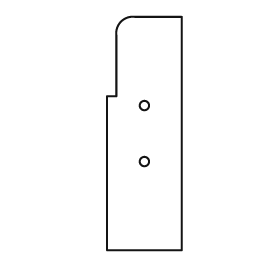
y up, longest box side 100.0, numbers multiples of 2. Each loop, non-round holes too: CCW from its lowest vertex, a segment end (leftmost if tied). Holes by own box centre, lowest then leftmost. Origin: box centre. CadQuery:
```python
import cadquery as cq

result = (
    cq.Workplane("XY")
    .moveTo(-16.0, -50.0)
    .lineTo(16.0, -50.0)
    .lineTo(16.0, 50.0)
    .lineTo(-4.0, 50.0)
    .threePointArc((-10.0, 48.0), (-12.0, 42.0))
    .lineTo(-12.0, 16.0)
    .lineTo(-16.0, 16.0)
    .close()
    .moveTo(0.0, -12.0)
    .circle(2.0)
    .moveTo(0.0, 12.0)
    .circle(2.0)
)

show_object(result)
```